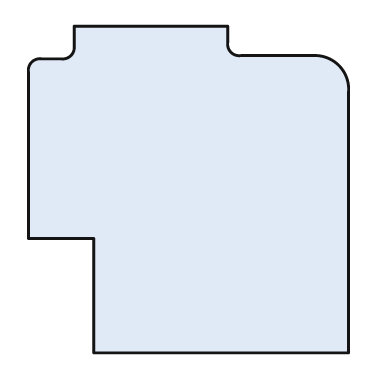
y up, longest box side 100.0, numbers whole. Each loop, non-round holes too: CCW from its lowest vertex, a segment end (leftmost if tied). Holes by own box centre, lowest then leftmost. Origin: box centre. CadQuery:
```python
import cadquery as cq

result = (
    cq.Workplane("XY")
    .moveTo(-29.0, -50.0)
    .lineTo(49.0, -50.0)
    .lineTo(49.0, 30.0)
    .threePointArc((46.0, 38.0), (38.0, 41.0))
    .lineTo(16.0, 41.0)
    .threePointArc((13.0, 42.0), (12.0, 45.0))
    .lineTo(12.0, 50.0)
    .lineTo(-35.0, 50.0)
    .lineTo(-35.0, 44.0)
    .threePointArc((-36.0, 41.0), (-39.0, 40.0))
    .lineTo(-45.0, 40.0)
    .threePointArc((-48.0, 39.0), (-49.0, 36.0))
    .lineTo(-49.0, -15.0)
    .lineTo(-29.0, -15.0)
    .close()
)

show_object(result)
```